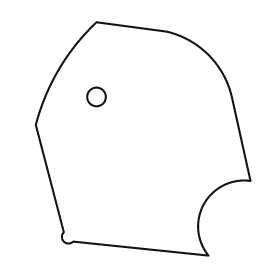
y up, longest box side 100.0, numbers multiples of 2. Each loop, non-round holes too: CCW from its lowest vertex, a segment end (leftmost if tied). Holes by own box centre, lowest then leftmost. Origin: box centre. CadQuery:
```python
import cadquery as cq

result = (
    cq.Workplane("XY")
    .moveTo(28.0, -50.0)
    .threePointArc((26.0, -28.0), (46.0, -18.0))
    .lineTo(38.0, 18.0)
    .threePointArc((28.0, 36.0), (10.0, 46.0))
    .lineTo(-20.0, 50.0)
    .threePointArc((-36.0, 30.0), (-46.0, 6.0))
    .lineTo(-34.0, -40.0)
    .threePointArc((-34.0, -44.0), (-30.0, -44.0))
    .close()
    .moveTo(-20.0, 18.0)
    .circle(4.0)
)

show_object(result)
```